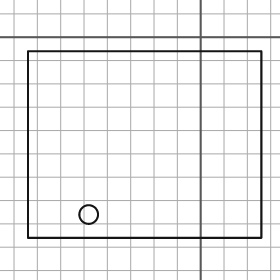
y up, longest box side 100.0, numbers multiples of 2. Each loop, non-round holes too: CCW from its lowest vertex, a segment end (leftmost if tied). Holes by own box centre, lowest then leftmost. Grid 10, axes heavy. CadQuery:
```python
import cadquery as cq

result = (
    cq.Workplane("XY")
    .moveTo(-74.0, -86.0)
    .lineTo(26.0, -86.0)
    .lineTo(26.0, -6.0)
    .lineTo(-74.0, -6.0)
    .close()
    .moveTo(-48.0, -76.0)
    .circle(4.0)
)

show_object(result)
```